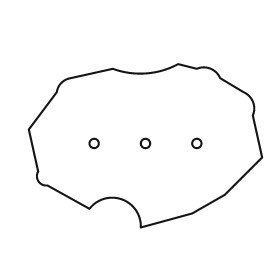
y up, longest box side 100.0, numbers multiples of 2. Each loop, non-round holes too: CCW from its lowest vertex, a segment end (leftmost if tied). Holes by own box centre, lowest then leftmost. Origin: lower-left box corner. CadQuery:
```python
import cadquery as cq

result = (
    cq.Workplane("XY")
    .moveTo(48.0, 0.0)
    .lineTo(70.0, 6.0)
    .lineTo(84.0, 14.0)
    .lineTo(100.0, 30.0)
    .lineTo(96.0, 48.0)
    .threePointArc((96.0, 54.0), (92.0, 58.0))
    .lineTo(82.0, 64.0)
    .threePointArc((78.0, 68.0), (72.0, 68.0))
    .lineTo(64.0, 70.0)
    .threePointArc((50.0, 66.0), (36.0, 68.0))
    .lineTo(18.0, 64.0)
    .threePointArc((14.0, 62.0), (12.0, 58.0))
    .lineTo(0.0, 42.0)
    .lineTo(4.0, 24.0)
    .threePointArc((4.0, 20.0), (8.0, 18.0))
    .lineTo(26.0, 8.0)
    .threePointArc((40.0, 12.0), (48.0, 0.0))
    .close()
    .moveTo(28.0, 36.0)
    .circle(2.0)
    .moveTo(50.0, 36.0)
    .circle(2.0)
    .moveTo(72.0, 36.0)
    .circle(2.0)
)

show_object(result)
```